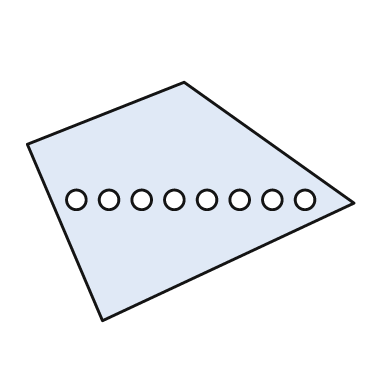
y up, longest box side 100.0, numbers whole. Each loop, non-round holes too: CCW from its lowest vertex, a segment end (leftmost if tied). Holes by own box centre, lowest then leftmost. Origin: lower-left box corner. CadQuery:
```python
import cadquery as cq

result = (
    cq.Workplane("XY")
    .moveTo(23.0, 0.0)
    .lineTo(100.0, 36.0)
    .lineTo(48.0, 73.0)
    .lineTo(0.0, 54.0)
    .close()
    .moveTo(15.0, 37.0)
    .circle(3.0)
    .moveTo(25.0, 37.0)
    .circle(3.0)
    .moveTo(35.0, 37.0)
    .circle(3.0)
    .moveTo(45.0, 37.0)
    .circle(3.0)
    .moveTo(55.0, 37.0)
    .circle(3.0)
    .moveTo(65.0, 37.0)
    .circle(3.0)
    .moveTo(75.0, 37.0)
    .circle(3.0)
    .moveTo(85.0, 37.0)
    .circle(3.0)
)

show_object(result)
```